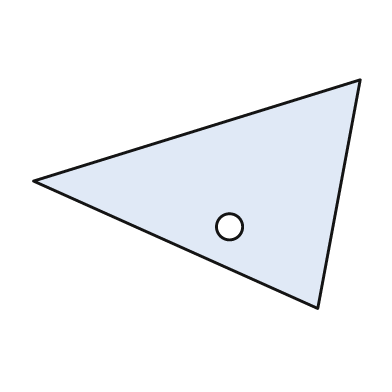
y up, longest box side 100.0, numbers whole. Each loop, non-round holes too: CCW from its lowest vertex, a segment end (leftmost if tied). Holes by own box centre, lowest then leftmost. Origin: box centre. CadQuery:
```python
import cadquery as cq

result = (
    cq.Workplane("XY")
    .moveTo(37.0, -35.0)
    .lineTo(50.0, 35.0)
    .lineTo(-50.0, 4.0)
    .close()
    .moveTo(10.0, -10.0)
    .circle(4.0)
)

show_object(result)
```